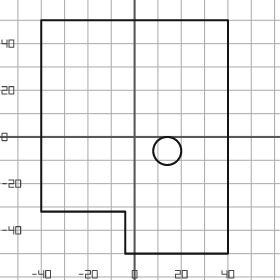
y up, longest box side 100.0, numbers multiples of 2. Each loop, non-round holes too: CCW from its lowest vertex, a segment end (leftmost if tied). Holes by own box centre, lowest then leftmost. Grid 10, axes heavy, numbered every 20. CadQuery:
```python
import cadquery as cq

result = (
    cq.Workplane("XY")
    .moveTo(-4.0, -50.0)
    .lineTo(40.0, -50.0)
    .lineTo(40.0, 50.0)
    .lineTo(-40.0, 50.0)
    .lineTo(-40.0, -32.0)
    .lineTo(-4.0, -32.0)
    .close()
    .moveTo(14.0, -6.0)
    .circle(6.0)
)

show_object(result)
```